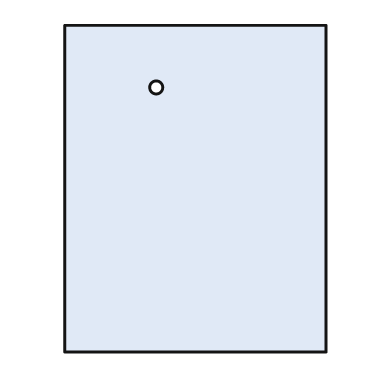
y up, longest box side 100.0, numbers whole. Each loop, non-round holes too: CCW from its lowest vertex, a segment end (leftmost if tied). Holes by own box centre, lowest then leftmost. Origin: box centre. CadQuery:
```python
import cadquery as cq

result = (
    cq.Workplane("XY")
    .moveTo(-40.0, -50.0)
    .lineTo(40.0, -50.0)
    .lineTo(40.0, 50.0)
    .lineTo(-40.0, 50.0)
    .close()
    .moveTo(-12.0, 31.0)
    .circle(2.0)
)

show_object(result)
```